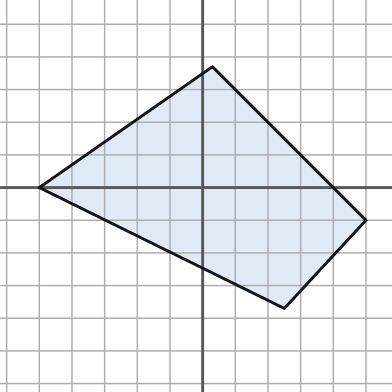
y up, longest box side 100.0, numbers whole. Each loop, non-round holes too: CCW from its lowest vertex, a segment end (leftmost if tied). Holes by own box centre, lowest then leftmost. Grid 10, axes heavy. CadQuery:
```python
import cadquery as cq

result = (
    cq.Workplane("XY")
    .moveTo(25.0, -37.0)
    .lineTo(50.0, -10.0)
    .lineTo(3.0, 37.0)
    .lineTo(-50.0, 0.0)
    .close()
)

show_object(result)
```